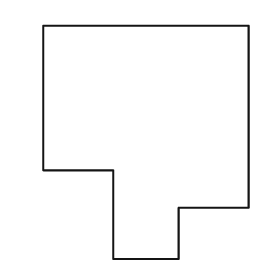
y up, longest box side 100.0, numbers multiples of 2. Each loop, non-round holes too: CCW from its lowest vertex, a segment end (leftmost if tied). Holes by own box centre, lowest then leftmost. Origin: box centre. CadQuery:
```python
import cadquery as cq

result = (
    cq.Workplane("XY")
    .moveTo(-14.0, -50.0)
    .lineTo(14.0, -50.0)
    .lineTo(14.0, -28.0)
    .lineTo(44.0, -28.0)
    .lineTo(44.0, 50.0)
    .lineTo(-44.0, 50.0)
    .lineTo(-44.0, -12.0)
    .lineTo(-14.0, -12.0)
    .close()
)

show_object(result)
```